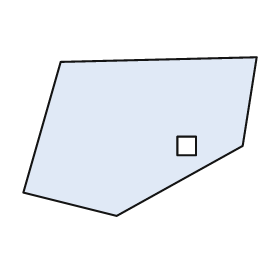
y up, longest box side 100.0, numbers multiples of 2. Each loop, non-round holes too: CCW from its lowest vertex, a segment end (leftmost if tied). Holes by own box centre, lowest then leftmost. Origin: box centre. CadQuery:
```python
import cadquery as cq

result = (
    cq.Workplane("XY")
    .moveTo(-10.0, -34.0)
    .lineTo(44.0, -4.0)
    .lineTo(50.0, 34.0)
    .lineTo(-34.0, 32.0)
    .lineTo(-50.0, -24.0)
    .close()
    .moveTo(16.0, -8.0)
    .lineTo(24.0, -8.0)
    .lineTo(24.0, 0.0)
    .lineTo(16.0, 0.0)
    .close()
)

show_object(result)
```